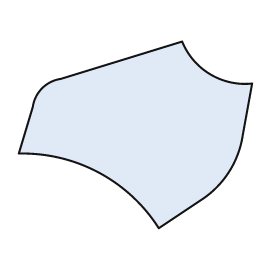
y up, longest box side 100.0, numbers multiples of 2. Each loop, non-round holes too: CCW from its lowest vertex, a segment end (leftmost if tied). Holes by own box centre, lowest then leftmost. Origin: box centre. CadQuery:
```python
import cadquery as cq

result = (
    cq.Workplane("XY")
    .moveTo(10.0, -40.0)
    .lineTo(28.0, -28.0)
    .threePointArc((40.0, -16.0), (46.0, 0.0))
    .lineTo(50.0, 22.0)
    .threePointArc((32.0, 26.0), (20.0, 40.0))
    .lineTo(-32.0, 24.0)
    .threePointArc((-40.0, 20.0), (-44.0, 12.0))
    .lineTo(-50.0, -8.0)
    .threePointArc((-16.0, -16.0), (10.0, -40.0))
    .close()
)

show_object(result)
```